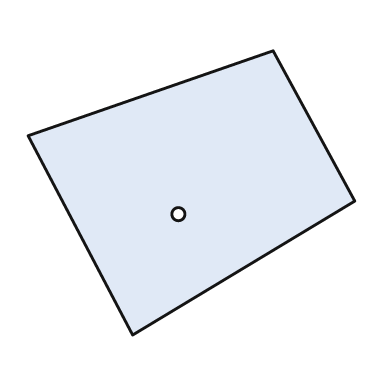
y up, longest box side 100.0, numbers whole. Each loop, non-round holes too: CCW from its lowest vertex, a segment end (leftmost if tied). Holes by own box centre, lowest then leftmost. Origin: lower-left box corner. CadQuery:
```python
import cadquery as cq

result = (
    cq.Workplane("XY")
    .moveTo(32.0, 0.0)
    .lineTo(100.0, 41.0)
    .lineTo(75.0, 87.0)
    .lineTo(0.0, 61.0)
    .close()
    .moveTo(46.0, 37.0)
    .circle(2.0)
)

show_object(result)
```